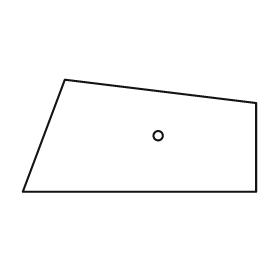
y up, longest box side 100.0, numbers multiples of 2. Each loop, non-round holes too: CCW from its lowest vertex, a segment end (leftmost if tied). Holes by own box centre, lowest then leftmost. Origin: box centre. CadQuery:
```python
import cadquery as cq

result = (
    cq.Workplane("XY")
    .moveTo(-50.0, -24.0)
    .lineTo(50.0, -24.0)
    .lineTo(50.0, 14.0)
    .lineTo(-32.0, 24.0)
    .close()
    .moveTo(8.0, 0.0)
    .circle(2.0)
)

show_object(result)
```